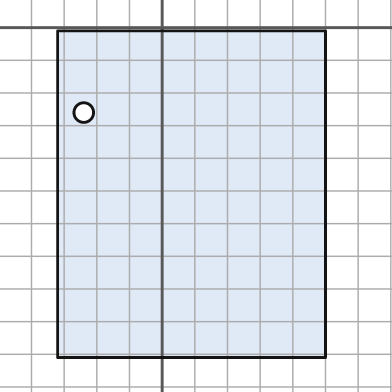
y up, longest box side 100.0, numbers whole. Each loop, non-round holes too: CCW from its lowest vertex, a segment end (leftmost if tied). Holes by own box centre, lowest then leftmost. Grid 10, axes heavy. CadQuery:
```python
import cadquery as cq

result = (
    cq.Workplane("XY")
    .moveTo(-32.0, -101.0)
    .lineTo(50.0, -101.0)
    .lineTo(50.0, -1.0)
    .lineTo(-32.0, -1.0)
    .close()
    .moveTo(-24.0, -26.0)
    .circle(3.0)
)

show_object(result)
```